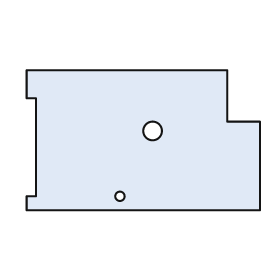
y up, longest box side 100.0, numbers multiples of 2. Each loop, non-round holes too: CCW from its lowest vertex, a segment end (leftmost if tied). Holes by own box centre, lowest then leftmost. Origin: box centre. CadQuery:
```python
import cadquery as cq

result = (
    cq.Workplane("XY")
    .moveTo(-50.0, -30.0)
    .lineTo(50.0, -30.0)
    .lineTo(50.0, 8.0)
    .lineTo(36.0, 8.0)
    .lineTo(36.0, 30.0)
    .lineTo(-50.0, 30.0)
    .lineTo(-50.0, 18.0)
    .lineTo(-46.0, 18.0)
    .lineTo(-46.0, -24.0)
    .lineTo(-50.0, -24.0)
    .close()
    .moveTo(-10.0, -24.0)
    .circle(2.0)
    .moveTo(4.0, 4.0)
    .circle(4.0)
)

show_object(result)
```